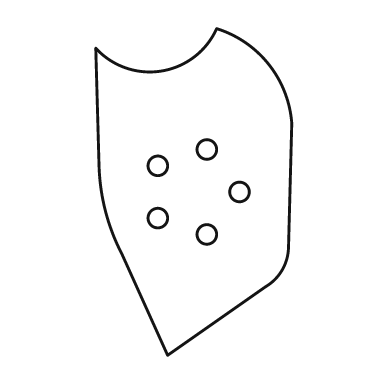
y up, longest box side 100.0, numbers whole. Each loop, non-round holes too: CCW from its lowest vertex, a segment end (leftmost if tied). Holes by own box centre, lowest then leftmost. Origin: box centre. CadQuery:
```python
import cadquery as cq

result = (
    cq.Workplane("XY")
    .moveTo(-8.0, -50.0)
    .lineTo(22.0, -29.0)
    .threePointArc((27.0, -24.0), (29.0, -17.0))
    .lineTo(30.0, 21.0)
    .threePointArc((23.0, 39.0), (7.0, 50.0))
    .threePointArc((-10.0, 37.0), (-30.0, 44.0))
    .lineTo(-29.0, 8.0)
    .threePointArc((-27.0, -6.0), (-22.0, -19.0))
    .close()
    .moveTo(4.0, -13.0)
    .circle(3.0)
    .moveTo(-11.0, -8.0)
    .circle(3.0)
    .moveTo(14.0, 0.0)
    .circle(3.0)
    .moveTo(-11.0, 8.0)
    .circle(3.0)
    .moveTo(4.0, 13.0)
    .circle(3.0)
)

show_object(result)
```